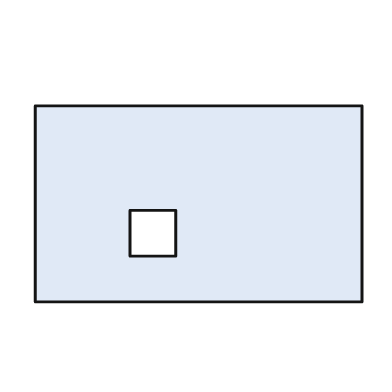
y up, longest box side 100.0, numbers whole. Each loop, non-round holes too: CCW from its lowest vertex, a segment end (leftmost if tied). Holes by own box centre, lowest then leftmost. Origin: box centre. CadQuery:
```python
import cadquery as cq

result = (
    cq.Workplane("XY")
    .moveTo(-50.0, -30.0)
    .lineTo(50.0, -30.0)
    .lineTo(50.0, 30.0)
    .lineTo(-50.0, 30.0)
    .close()
    .moveTo(-21.0, -16.0)
    .lineTo(-7.0, -16.0)
    .lineTo(-7.0, -2.0)
    .lineTo(-21.0, -2.0)
    .close()
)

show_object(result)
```